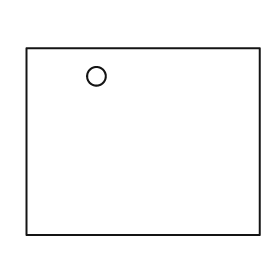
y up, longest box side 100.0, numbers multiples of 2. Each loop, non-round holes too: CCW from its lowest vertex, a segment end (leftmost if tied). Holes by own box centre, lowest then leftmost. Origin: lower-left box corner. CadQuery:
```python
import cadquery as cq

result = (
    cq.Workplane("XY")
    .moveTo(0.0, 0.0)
    .lineTo(100.0, 0.0)
    .lineTo(100.0, 80.0)
    .lineTo(0.0, 80.0)
    .close()
    .moveTo(30.0, 68.0)
    .circle(4.0)
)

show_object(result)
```